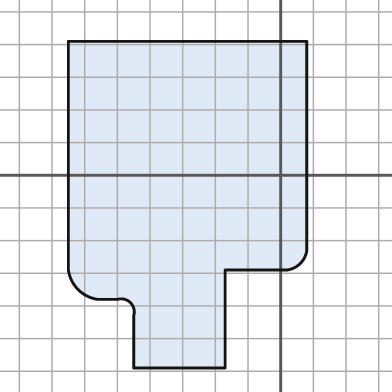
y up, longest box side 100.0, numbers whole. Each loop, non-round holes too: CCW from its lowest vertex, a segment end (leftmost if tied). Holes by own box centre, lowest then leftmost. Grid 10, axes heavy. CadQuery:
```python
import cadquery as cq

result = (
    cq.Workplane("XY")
    .moveTo(-45.0, -59.0)
    .lineTo(-17.0, -59.0)
    .lineTo(-17.0, -29.0)
    .lineTo(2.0, -29.0)
    .threePointArc((6.0, -27.0), (8.0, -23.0))
    .lineTo(8.0, 41.0)
    .lineTo(-65.0, 41.0)
    .lineTo(-65.0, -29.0)
    .threePointArc((-62.0, -35.0), (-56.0, -38.0))
    .lineTo(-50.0, -38.0)
    .threePointArc((-46.0, -39.0), (-45.0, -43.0))
    .close()
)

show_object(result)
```